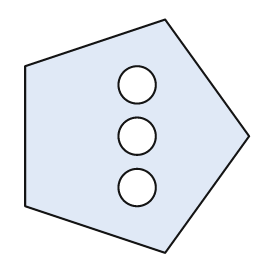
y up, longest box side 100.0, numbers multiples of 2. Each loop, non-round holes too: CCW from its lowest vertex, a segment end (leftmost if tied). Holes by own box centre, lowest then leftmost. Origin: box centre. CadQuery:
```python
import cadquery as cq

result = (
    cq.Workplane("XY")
    .moveTo(12.0, -50.0)
    .lineTo(48.0, 0.0)
    .lineTo(12.0, 50.0)
    .lineTo(-48.0, 30.0)
    .lineTo(-48.0, -30.0)
    .close()
    .moveTo(0.0, -22.0)
    .circle(8.0)
    .moveTo(0.0, 0.0)
    .circle(8.0)
    .moveTo(0.0, 22.0)
    .circle(8.0)
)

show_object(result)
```